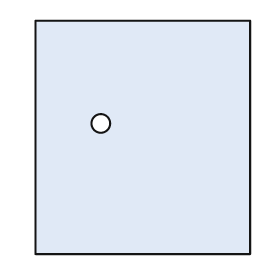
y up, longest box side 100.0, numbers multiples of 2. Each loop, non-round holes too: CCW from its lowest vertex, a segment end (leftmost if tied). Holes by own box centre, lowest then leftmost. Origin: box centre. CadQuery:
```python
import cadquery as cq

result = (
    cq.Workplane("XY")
    .moveTo(-46.0, -50.0)
    .lineTo(46.0, -50.0)
    .lineTo(46.0, 50.0)
    .lineTo(-46.0, 50.0)
    .close()
    .moveTo(-18.0, 6.0)
    .circle(4.0)
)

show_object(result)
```